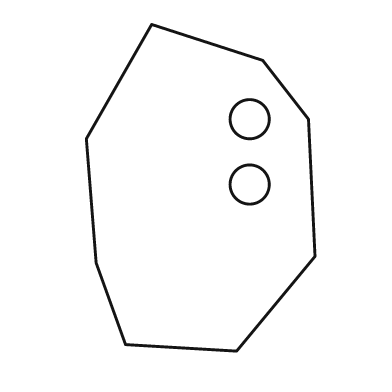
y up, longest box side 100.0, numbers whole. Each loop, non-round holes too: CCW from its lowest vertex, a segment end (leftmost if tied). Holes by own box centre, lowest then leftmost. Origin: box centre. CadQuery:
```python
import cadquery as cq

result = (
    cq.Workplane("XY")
    .moveTo(11.0, -50.0)
    .lineTo(35.0, -21.0)
    .lineTo(33.0, 21.0)
    .lineTo(19.0, 39.0)
    .lineTo(-15.0, 50.0)
    .lineTo(-35.0, 15.0)
    .lineTo(-32.0, -23.0)
    .lineTo(-23.0, -48.0)
    .close()
    .moveTo(15.0, 1.0)
    .circle(6.0)
    .moveTo(15.0, 21.0)
    .circle(6.0)
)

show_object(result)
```